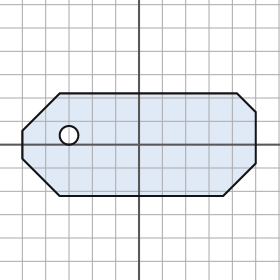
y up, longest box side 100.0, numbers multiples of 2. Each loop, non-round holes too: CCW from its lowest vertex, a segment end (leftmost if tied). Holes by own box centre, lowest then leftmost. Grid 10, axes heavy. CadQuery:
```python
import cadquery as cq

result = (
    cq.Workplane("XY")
    .moveTo(-34.0, -22.0)
    .lineTo(36.0, -22.0)
    .lineTo(50.0, -8.0)
    .lineTo(50.0, 14.0)
    .lineTo(42.0, 22.0)
    .lineTo(-34.0, 22.0)
    .lineTo(-50.0, 6.0)
    .lineTo(-50.0, -6.0)
    .close()
    .moveTo(-30.0, 4.0)
    .circle(4.0)
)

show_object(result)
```